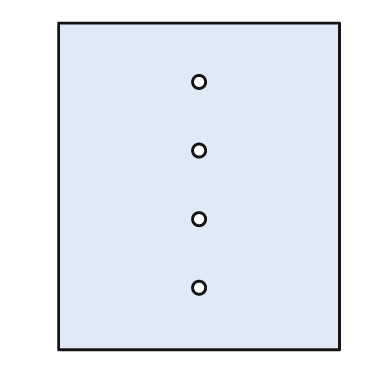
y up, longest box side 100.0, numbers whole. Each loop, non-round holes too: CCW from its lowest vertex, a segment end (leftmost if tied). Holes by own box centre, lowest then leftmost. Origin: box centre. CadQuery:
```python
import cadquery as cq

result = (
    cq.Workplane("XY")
    .moveTo(-43.0, -50.0)
    .lineTo(43.0, -50.0)
    .lineTo(43.0, 50.0)
    .lineTo(-43.0, 50.0)
    .close()
    .moveTo(0.0, -31.0)
    .circle(2.0)
    .moveTo(0.0, -10.0)
    .circle(2.0)
    .moveTo(0.0, 11.0)
    .circle(2.0)
    .moveTo(0.0, 32.0)
    .circle(2.0)
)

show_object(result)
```